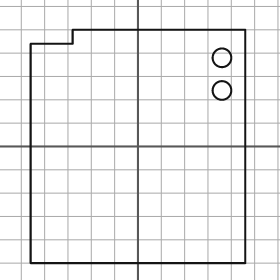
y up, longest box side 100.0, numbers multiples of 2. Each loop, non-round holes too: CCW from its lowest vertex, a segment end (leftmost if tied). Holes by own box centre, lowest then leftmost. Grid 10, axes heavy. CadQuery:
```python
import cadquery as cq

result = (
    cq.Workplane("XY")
    .moveTo(-46.0, -50.0)
    .lineTo(46.0, -50.0)
    .lineTo(46.0, 50.0)
    .lineTo(-28.0, 50.0)
    .lineTo(-28.0, 44.0)
    .lineTo(-46.0, 44.0)
    .close()
    .moveTo(36.0, 24.0)
    .circle(4.0)
    .moveTo(36.0, 38.0)
    .circle(4.0)
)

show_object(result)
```